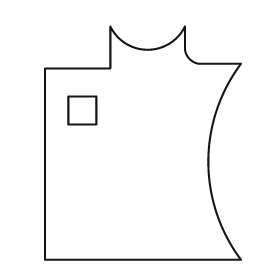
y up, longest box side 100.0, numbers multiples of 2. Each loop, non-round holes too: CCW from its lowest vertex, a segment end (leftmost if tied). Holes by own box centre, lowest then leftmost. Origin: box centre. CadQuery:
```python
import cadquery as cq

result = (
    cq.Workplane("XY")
    .moveTo(-42.0, -50.0)
    .lineTo(42.0, -50.0)
    .threePointArc((28.0, -8.0), (42.0, 34.0))
    .lineTo(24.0, 34.0)
    .threePointArc((20.0, 36.0), (18.0, 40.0))
    .lineTo(18.0, 50.0)
    .threePointArc((2.0, 40.0), (-14.0, 50.0))
    .lineTo(-14.0, 32.0)
    .lineTo(-42.0, 32.0)
    .close()
    .moveTo(-32.0, 8.0)
    .lineTo(-20.0, 8.0)
    .lineTo(-20.0, 20.0)
    .lineTo(-32.0, 20.0)
    .close()
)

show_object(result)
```